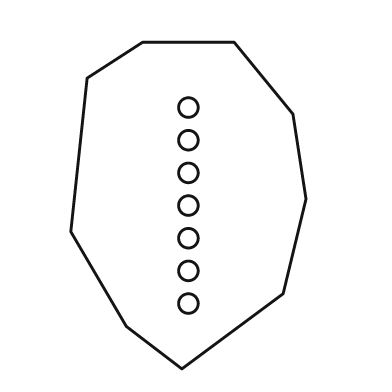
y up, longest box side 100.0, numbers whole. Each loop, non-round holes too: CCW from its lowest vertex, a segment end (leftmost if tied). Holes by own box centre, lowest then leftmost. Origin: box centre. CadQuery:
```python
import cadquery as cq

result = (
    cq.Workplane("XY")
    .moveTo(-2.0, -50.0)
    .lineTo(29.0, -27.0)
    .lineTo(36.0, 2.0)
    .lineTo(32.0, 28.0)
    .lineTo(14.0, 50.0)
    .lineTo(-14.0, 50.0)
    .lineTo(-31.0, 39.0)
    .lineTo(-36.0, -8.0)
    .lineTo(-19.0, -37.0)
    .close()
    .moveTo(0.0, -30.0)
    .circle(3.0)
    .moveTo(0.0, -20.0)
    .circle(3.0)
    .moveTo(0.0, -10.0)
    .circle(3.0)
    .moveTo(0.0, 0.0)
    .circle(3.0)
    .moveTo(0.0, 10.0)
    .circle(3.0)
    .moveTo(0.0, 20.0)
    .circle(3.0)
    .moveTo(0.0, 30.0)
    .circle(3.0)
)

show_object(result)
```